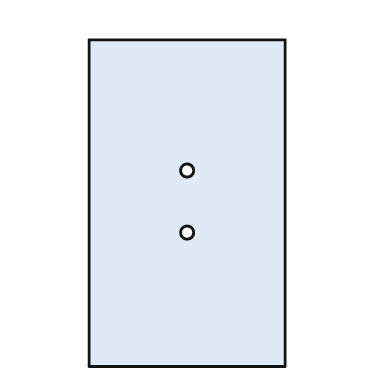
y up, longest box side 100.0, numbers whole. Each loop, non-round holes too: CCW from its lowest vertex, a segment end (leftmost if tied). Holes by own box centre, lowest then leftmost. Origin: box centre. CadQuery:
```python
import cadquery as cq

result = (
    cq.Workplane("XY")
    .moveTo(-30.0, -50.0)
    .lineTo(30.0, -50.0)
    .lineTo(30.0, 50.0)
    .lineTo(-30.0, 50.0)
    .close()
    .moveTo(0.0, -9.0)
    .circle(2.0)
    .moveTo(0.0, 10.0)
    .circle(2.0)
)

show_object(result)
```